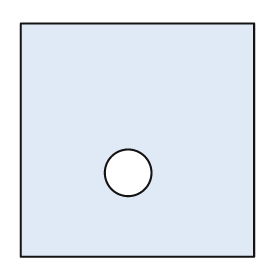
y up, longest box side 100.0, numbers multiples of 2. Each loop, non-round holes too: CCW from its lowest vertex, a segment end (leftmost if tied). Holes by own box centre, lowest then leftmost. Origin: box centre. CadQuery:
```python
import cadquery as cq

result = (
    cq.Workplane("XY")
    .moveTo(-50.0, -50.0)
    .lineTo(50.0, -50.0)
    .lineTo(50.0, 50.0)
    .lineTo(-50.0, 50.0)
    .close()
    .moveTo(-4.0, -14.0)
    .circle(10.0)
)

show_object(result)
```